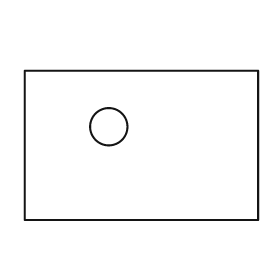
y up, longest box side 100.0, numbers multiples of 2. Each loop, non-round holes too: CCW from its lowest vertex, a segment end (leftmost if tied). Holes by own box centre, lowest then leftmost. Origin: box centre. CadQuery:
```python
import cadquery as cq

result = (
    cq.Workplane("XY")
    .moveTo(-50.0, -32.0)
    .lineTo(50.0, -32.0)
    .lineTo(50.0, 32.0)
    .lineTo(-50.0, 32.0)
    .close()
    .moveTo(-14.0, 8.0)
    .circle(8.0)
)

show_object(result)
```